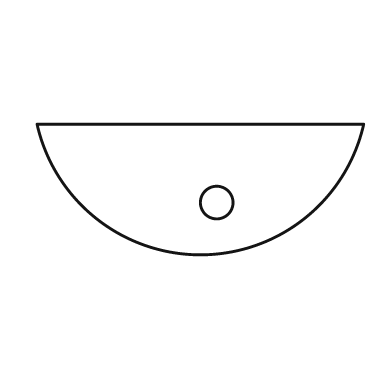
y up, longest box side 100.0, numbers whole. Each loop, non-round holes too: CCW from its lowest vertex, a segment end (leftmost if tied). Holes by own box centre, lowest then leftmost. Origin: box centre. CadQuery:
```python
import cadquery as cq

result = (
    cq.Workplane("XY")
    .moveTo(-50.0, 20.0)
    .threePointArc((0.0, -20.0), (50.0, 20.0))
    .close()
    .moveTo(5.0, -4.0)
    .circle(5.0)
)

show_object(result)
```